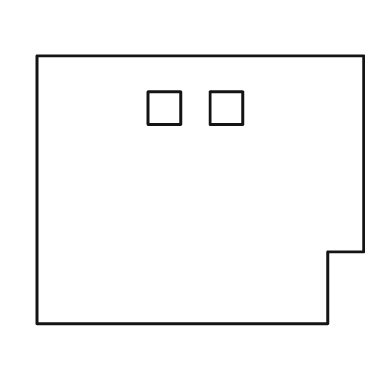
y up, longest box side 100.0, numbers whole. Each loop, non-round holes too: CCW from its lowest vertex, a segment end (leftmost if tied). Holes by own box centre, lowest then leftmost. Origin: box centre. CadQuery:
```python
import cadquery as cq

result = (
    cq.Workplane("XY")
    .moveTo(-50.0, -41.0)
    .lineTo(39.0, -41.0)
    .lineTo(39.0, -19.0)
    .lineTo(50.0, -19.0)
    .lineTo(50.0, 41.0)
    .lineTo(-50.0, 41.0)
    .close()
    .moveTo(-16.0, 20.0)
    .lineTo(-6.0, 20.0)
    .lineTo(-6.0, 30.0)
    .lineTo(-16.0, 30.0)
    .close()
    .moveTo(3.0, 20.0)
    .lineTo(13.0, 20.0)
    .lineTo(13.0, 30.0)
    .lineTo(3.0, 30.0)
    .close()
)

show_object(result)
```